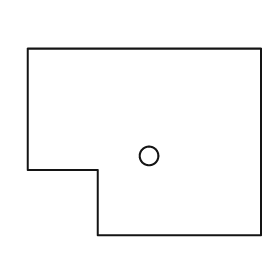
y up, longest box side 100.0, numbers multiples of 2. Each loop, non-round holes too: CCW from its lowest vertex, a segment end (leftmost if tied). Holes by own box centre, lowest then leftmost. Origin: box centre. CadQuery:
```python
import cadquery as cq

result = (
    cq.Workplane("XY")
    .moveTo(-20.0, -40.0)
    .lineTo(50.0, -40.0)
    .lineTo(50.0, 40.0)
    .lineTo(-50.0, 40.0)
    .lineTo(-50.0, -12.0)
    .lineTo(-20.0, -12.0)
    .close()
    .moveTo(2.0, -6.0)
    .circle(4.0)
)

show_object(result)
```